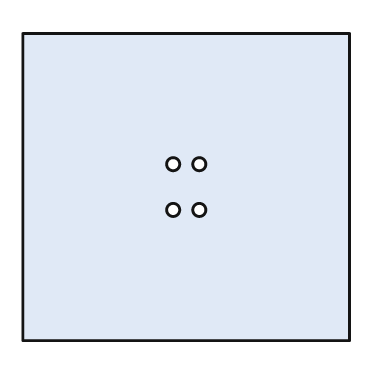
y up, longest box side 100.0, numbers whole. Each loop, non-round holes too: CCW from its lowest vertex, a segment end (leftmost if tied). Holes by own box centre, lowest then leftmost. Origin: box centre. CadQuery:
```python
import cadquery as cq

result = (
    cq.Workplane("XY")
    .moveTo(-50.0, -47.0)
    .lineTo(50.0, -47.0)
    .lineTo(50.0, 47.0)
    .lineTo(-50.0, 47.0)
    .close()
    .moveTo(-4.0, -7.0)
    .circle(2.0)
    .moveTo(4.0, -7.0)
    .circle(2.0)
    .moveTo(-4.0, 7.0)
    .circle(2.0)
    .moveTo(4.0, 7.0)
    .circle(2.0)
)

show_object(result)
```